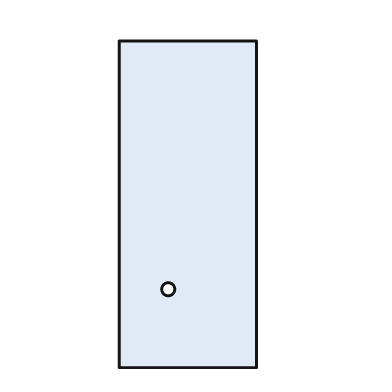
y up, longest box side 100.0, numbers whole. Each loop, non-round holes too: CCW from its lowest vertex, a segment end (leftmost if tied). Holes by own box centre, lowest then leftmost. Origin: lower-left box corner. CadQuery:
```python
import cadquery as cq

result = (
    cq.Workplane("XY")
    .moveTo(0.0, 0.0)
    .lineTo(42.0, 0.0)
    .lineTo(42.0, 100.0)
    .lineTo(0.0, 100.0)
    .close()
    .moveTo(15.0, 24.0)
    .circle(2.0)
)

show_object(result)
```